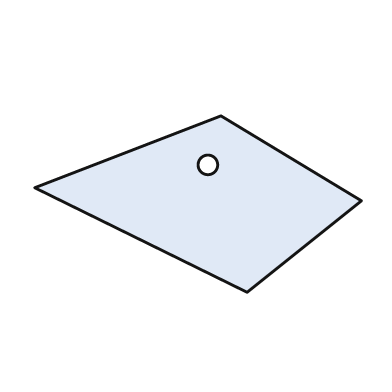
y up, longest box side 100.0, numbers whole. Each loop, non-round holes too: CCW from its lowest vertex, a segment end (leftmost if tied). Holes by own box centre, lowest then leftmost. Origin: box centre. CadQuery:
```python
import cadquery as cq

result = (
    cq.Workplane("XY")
    .moveTo(15.0, -27.0)
    .lineTo(50.0, 1.0)
    .lineTo(7.0, 27.0)
    .lineTo(-50.0, 5.0)
    .close()
    .moveTo(3.0, 12.0)
    .circle(3.0)
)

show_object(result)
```